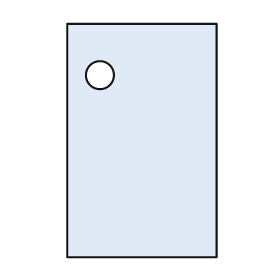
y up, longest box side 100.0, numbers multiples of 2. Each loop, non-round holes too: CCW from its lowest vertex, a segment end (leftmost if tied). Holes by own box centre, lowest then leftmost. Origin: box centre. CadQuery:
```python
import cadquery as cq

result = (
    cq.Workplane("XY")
    .moveTo(-32.0, -50.0)
    .lineTo(32.0, -50.0)
    .lineTo(32.0, 50.0)
    .lineTo(-32.0, 50.0)
    .close()
    .moveTo(-18.0, 28.0)
    .circle(6.0)
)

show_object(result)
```